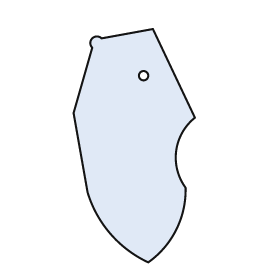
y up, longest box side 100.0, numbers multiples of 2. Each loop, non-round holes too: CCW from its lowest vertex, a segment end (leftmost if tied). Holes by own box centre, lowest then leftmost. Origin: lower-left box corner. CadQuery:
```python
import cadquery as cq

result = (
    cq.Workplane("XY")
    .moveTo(32.0, 0.0)
    .threePointArc((44.0, 14.0), (48.0, 32.0))
    .threePointArc((44.0, 48.0), (52.0, 62.0))
    .lineTo(34.0, 100.0)
    .lineTo(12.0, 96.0)
    .threePointArc((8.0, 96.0), (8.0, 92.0))
    .lineTo(0.0, 64.0)
    .lineTo(6.0, 30.0)
    .threePointArc((16.0, 12.0), (32.0, 0.0))
    .close()
    .moveTo(30.0, 80.0)
    .circle(2.0)
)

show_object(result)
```